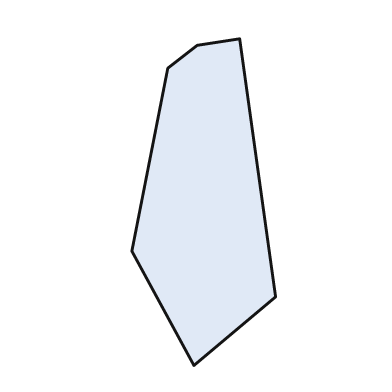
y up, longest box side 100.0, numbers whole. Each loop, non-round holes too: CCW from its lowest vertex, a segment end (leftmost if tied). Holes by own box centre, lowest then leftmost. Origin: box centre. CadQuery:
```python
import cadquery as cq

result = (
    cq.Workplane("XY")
    .moveTo(-3.0, -50.0)
    .lineTo(22.0, -29.0)
    .lineTo(11.0, 50.0)
    .lineTo(-2.0, 48.0)
    .lineTo(-11.0, 41.0)
    .lineTo(-22.0, -15.0)
    .close()
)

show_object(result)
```